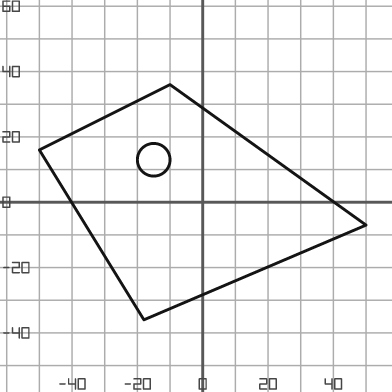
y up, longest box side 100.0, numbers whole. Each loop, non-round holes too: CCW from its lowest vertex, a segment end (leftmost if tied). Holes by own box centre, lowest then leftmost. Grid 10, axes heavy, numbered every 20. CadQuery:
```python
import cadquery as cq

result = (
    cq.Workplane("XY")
    .moveTo(-18.0, -36.0)
    .lineTo(50.0, -7.0)
    .lineTo(-10.0, 36.0)
    .lineTo(-50.0, 16.0)
    .close()
    .moveTo(-15.0, 13.0)
    .circle(5.0)
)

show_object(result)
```